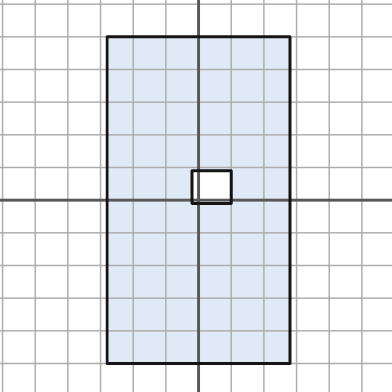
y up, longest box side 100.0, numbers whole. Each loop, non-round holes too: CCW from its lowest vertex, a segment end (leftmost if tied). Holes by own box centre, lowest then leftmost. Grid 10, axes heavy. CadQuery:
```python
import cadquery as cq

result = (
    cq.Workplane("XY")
    .moveTo(-28.0, -50.0)
    .lineTo(28.0, -50.0)
    .lineTo(28.0, 50.0)
    .lineTo(-28.0, 50.0)
    .close()
    .moveTo(-2.0, -1.0)
    .lineTo(10.0, -1.0)
    .lineTo(10.0, 9.0)
    .lineTo(-2.0, 9.0)
    .close()
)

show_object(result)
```